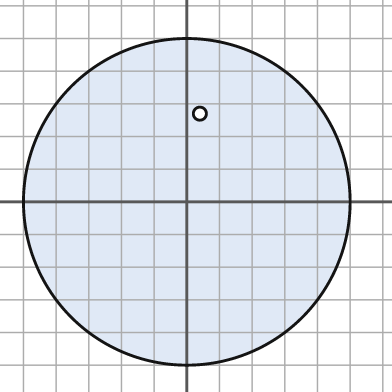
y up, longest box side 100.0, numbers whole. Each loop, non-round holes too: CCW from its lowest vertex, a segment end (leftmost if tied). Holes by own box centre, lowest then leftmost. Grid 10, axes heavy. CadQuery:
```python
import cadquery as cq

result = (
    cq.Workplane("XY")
    .moveTo(0.0, 0.0)
    .circle(50.0)
    .moveTo(4.0, 27.0)
    .circle(2.0)
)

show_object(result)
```